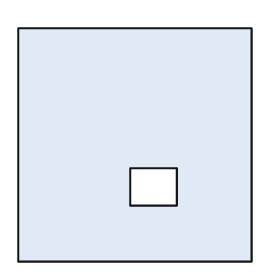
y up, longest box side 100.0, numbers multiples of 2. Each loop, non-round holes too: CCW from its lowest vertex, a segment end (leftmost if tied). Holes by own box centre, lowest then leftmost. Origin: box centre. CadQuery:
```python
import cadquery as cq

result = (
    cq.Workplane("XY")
    .moveTo(-50.0, -50.0)
    .lineTo(50.0, -50.0)
    .lineTo(50.0, 50.0)
    .lineTo(-50.0, 50.0)
    .close()
    .moveTo(-2.0, -26.0)
    .lineTo(18.0, -26.0)
    .lineTo(18.0, -10.0)
    .lineTo(-2.0, -10.0)
    .close()
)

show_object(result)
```